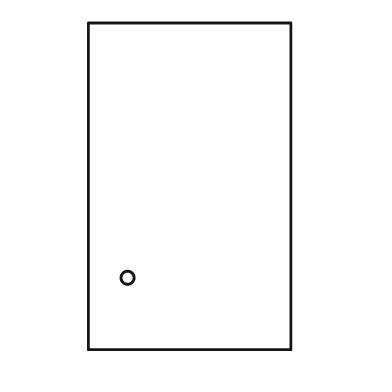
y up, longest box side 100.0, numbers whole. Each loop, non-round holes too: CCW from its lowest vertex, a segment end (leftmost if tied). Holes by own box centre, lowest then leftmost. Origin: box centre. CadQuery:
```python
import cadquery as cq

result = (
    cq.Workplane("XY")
    .moveTo(-31.0, -50.0)
    .lineTo(31.0, -50.0)
    .lineTo(31.0, 50.0)
    .lineTo(-31.0, 50.0)
    .close()
    .moveTo(-19.0, -28.0)
    .circle(2.0)
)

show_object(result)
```